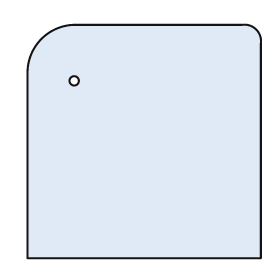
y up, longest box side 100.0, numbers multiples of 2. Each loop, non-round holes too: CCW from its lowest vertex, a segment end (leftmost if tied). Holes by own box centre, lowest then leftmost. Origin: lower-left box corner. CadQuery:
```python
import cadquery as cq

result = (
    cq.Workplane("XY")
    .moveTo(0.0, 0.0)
    .lineTo(100.0, 0.0)
    .lineTo(100.0, 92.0)
    .threePointArc((98.0, 98.0), (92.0, 100.0))
    .lineTo(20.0, 100.0)
    .threePointArc((6.0, 94.0), (0.0, 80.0))
    .close()
    .moveTo(20.0, 76.0)
    .circle(2.0)
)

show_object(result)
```